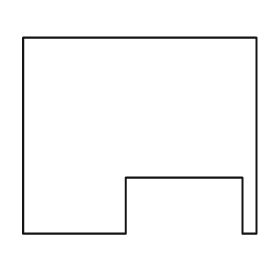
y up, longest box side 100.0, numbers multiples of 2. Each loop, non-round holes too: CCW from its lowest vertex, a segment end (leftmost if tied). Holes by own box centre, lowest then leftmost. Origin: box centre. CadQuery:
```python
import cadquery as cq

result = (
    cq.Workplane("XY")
    .moveTo(-50.0, -42.0)
    .lineTo(-6.0, -42.0)
    .lineTo(-6.0, -18.0)
    .lineTo(44.0, -18.0)
    .lineTo(44.0, -42.0)
    .lineTo(50.0, -42.0)
    .lineTo(50.0, 42.0)
    .lineTo(-50.0, 42.0)
    .close()
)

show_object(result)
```